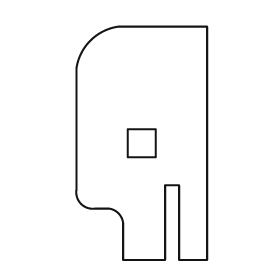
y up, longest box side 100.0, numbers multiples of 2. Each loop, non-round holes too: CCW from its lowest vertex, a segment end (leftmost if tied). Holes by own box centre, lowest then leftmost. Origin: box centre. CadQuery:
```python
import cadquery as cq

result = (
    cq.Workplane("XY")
    .moveTo(-8.0, -50.0)
    .lineTo(10.0, -50.0)
    .lineTo(10.0, -18.0)
    .lineTo(16.0, -18.0)
    .lineTo(16.0, -50.0)
    .lineTo(28.0, -50.0)
    .lineTo(28.0, 50.0)
    .lineTo(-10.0, 50.0)
    .threePointArc((-22.0, 44.0), (-28.0, 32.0))
    .lineTo(-28.0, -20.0)
    .threePointArc((-26.0, -26.0), (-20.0, -28.0))
    .lineTo(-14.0, -28.0)
    .threePointArc((-10.0, -30.0), (-8.0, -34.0))
    .close()
    .moveTo(-6.0, -6.0)
    .lineTo(6.0, -6.0)
    .lineTo(6.0, 6.0)
    .lineTo(-6.0, 6.0)
    .close()
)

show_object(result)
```